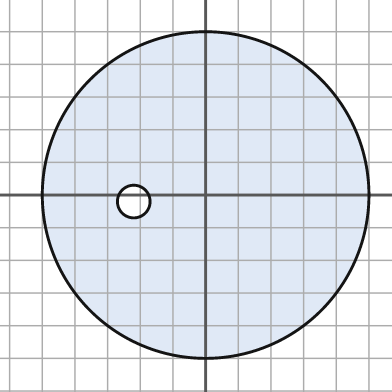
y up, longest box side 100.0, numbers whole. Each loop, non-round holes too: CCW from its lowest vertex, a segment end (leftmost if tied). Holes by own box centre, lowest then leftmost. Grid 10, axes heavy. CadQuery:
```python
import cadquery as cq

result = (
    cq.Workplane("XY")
    .moveTo(0.0, 0.0)
    .circle(50.0)
    .moveTo(-22.0, -2.0)
    .circle(5.0)
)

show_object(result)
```